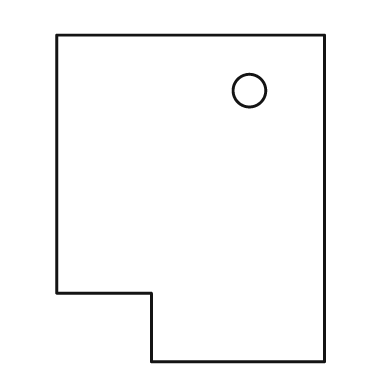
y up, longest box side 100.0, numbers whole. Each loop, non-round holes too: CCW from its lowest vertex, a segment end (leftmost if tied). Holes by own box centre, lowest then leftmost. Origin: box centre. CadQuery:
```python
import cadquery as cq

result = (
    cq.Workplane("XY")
    .moveTo(-12.0, -50.0)
    .lineTo(41.0, -50.0)
    .lineTo(41.0, 50.0)
    .lineTo(-41.0, 50.0)
    .lineTo(-41.0, -29.0)
    .lineTo(-12.0, -29.0)
    .close()
    .moveTo(18.0, 33.0)
    .circle(5.0)
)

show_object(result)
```